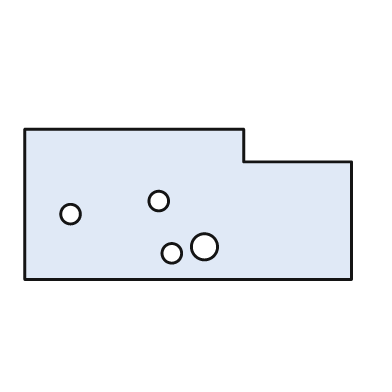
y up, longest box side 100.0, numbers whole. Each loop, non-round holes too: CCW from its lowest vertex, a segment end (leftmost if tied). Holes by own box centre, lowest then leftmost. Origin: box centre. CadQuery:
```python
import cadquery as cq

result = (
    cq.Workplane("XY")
    .moveTo(-50.0, -23.0)
    .lineTo(50.0, -23.0)
    .lineTo(50.0, 13.0)
    .lineTo(17.0, 13.0)
    .lineTo(17.0, 23.0)
    .lineTo(-50.0, 23.0)
    .close()
    .moveTo(-5.0, -15.0)
    .circle(3.0)
    .moveTo(5.0, -13.0)
    .circle(4.0)
    .moveTo(-36.0, -3.0)
    .circle(3.0)
    .moveTo(-9.0, 1.0)
    .circle(3.0)
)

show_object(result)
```